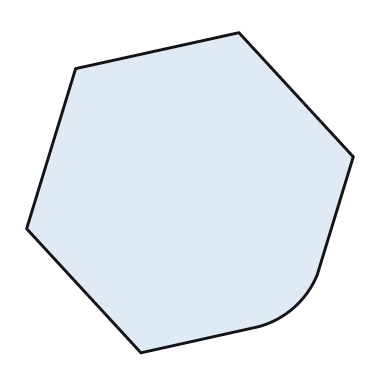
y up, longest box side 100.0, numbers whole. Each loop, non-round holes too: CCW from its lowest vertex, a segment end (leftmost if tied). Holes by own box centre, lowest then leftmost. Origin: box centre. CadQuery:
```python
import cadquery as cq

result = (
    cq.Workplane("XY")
    .moveTo(-15.0, -49.0)
    .lineTo(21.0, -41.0)
    .threePointArc((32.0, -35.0), (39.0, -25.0))
    .lineTo(50.0, 11.0)
    .lineTo(15.0, 49.0)
    .lineTo(-35.0, 38.0)
    .lineTo(-50.0, -11.0)
    .close()
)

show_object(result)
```